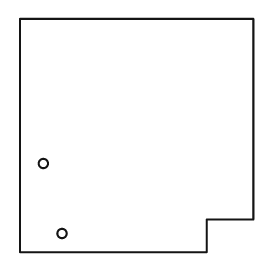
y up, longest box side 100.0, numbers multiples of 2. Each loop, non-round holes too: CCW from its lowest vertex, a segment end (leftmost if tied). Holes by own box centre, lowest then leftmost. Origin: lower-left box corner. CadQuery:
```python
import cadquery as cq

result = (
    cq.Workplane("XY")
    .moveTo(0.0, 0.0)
    .lineTo(80.0, 0.0)
    .lineTo(80.0, 14.0)
    .lineTo(100.0, 14.0)
    .lineTo(100.0, 100.0)
    .lineTo(0.0, 100.0)
    .close()
    .moveTo(18.0, 8.0)
    .circle(2.0)
    .moveTo(10.0, 38.0)
    .circle(2.0)
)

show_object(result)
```